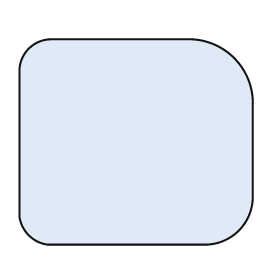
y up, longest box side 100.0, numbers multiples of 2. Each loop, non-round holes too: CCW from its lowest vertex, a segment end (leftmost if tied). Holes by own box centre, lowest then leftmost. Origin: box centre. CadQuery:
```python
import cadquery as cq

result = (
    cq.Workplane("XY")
    .moveTo(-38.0, -44.0)
    .lineTo(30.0, -44.0)
    .threePointArc((44.0, -38.0), (50.0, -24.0))
    .lineTo(50.0, 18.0)
    .threePointArc((42.0, 36.0), (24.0, 44.0))
    .lineTo(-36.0, 44.0)
    .threePointArc((-46.0, 40.0), (-50.0, 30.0))
    .lineTo(-50.0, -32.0)
    .threePointArc((-46.0, -40.0), (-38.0, -44.0))
    .close()
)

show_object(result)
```